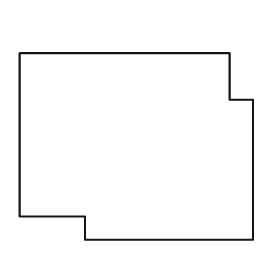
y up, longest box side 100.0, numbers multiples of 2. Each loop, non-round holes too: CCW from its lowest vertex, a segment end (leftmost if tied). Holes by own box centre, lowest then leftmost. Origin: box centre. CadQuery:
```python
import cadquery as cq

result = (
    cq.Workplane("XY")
    .moveTo(-22.0, -40.0)
    .lineTo(50.0, -40.0)
    .lineTo(50.0, 20.0)
    .lineTo(40.0, 20.0)
    .lineTo(40.0, 40.0)
    .lineTo(-50.0, 40.0)
    .lineTo(-50.0, -30.0)
    .lineTo(-22.0, -30.0)
    .close()
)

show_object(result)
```